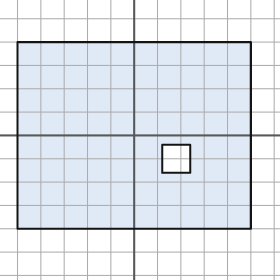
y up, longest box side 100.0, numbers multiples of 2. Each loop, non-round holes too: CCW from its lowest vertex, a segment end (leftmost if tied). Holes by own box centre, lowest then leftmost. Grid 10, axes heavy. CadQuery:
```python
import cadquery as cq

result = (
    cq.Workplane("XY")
    .moveTo(-50.0, -40.0)
    .lineTo(50.0, -40.0)
    .lineTo(50.0, 40.0)
    .lineTo(-50.0, 40.0)
    .close()
    .moveTo(12.0, -16.0)
    .lineTo(24.0, -16.0)
    .lineTo(24.0, -4.0)
    .lineTo(12.0, -4.0)
    .close()
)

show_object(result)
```